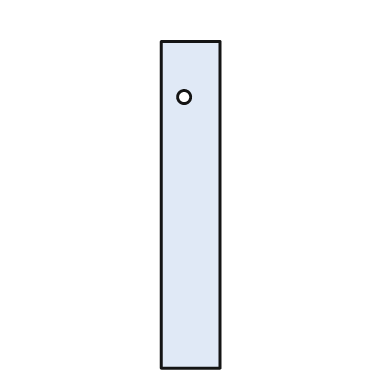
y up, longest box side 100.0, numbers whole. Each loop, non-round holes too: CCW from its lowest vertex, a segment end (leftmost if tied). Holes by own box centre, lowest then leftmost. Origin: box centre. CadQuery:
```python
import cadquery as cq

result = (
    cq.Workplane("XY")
    .moveTo(-9.0, -50.0)
    .lineTo(9.0, -50.0)
    .lineTo(9.0, 50.0)
    .lineTo(-9.0, 50.0)
    .close()
    .moveTo(-2.0, 33.0)
    .circle(2.0)
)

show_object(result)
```